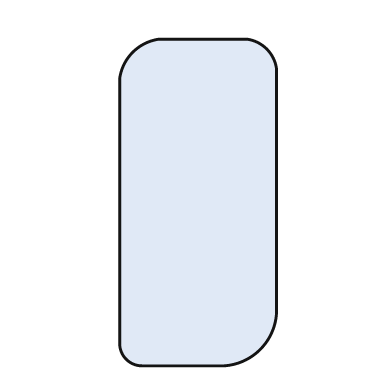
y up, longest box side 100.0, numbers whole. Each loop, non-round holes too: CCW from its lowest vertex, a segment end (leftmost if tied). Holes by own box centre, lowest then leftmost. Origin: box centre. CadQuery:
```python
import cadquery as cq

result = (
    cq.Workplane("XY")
    .moveTo(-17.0, -50.0)
    .lineTo(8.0, -50.0)
    .threePointArc((19.0, -45.0), (24.0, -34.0))
    .lineTo(24.0, 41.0)
    .threePointArc((21.0, 47.0), (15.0, 50.0))
    .lineTo(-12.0, 50.0)
    .threePointArc((-20.0, 46.0), (-24.0, 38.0))
    .lineTo(-24.0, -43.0)
    .threePointArc((-22.0, -48.0), (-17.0, -50.0))
    .close()
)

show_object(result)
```